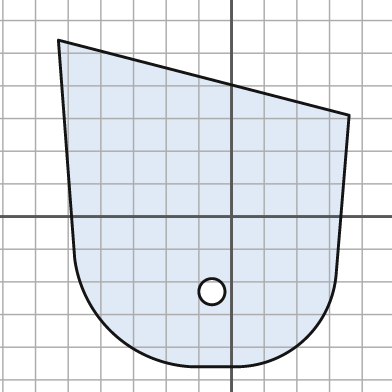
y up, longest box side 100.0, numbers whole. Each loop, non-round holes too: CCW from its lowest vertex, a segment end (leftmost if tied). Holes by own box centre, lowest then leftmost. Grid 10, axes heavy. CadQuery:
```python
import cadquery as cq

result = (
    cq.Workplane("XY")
    .moveTo(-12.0, -46.0)
    .lineTo(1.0, -46.0)
    .threePointArc((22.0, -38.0), (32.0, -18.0))
    .lineTo(36.0, 31.0)
    .lineTo(-53.0, 54.0)
    .lineTo(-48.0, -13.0)
    .threePointArc((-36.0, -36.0), (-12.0, -46.0))
    .close()
    .moveTo(-6.0, -23.0)
    .circle(4.0)
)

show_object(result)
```